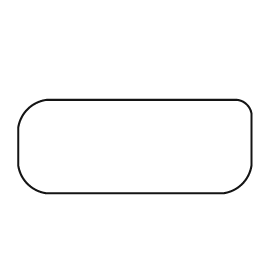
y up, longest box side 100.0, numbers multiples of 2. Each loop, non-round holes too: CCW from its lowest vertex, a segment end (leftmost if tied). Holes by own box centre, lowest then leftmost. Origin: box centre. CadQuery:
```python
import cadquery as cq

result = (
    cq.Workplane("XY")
    .moveTo(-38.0, -20.0)
    .lineTo(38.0, -20.0)
    .threePointArc((46.0, -16.0), (50.0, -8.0))
    .lineTo(50.0, 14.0)
    .threePointArc((48.0, 18.0), (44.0, 20.0))
    .lineTo(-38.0, 20.0)
    .threePointArc((-46.0, 16.0), (-50.0, 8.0))
    .lineTo(-50.0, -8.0)
    .threePointArc((-46.0, -16.0), (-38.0, -20.0))
    .close()
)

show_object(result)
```